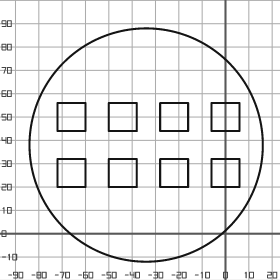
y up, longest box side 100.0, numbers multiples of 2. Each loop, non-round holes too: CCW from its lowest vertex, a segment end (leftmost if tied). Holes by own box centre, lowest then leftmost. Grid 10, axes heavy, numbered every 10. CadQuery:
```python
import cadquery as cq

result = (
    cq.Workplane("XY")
    .moveTo(-34.0, 38.0)
    .circle(50.0)
    .moveTo(-72.0, 20.0)
    .lineTo(-60.0, 20.0)
    .lineTo(-60.0, 32.0)
    .lineTo(-72.0, 32.0)
    .close()
    .moveTo(-50.0, 20.0)
    .lineTo(-38.0, 20.0)
    .lineTo(-38.0, 32.0)
    .lineTo(-50.0, 32.0)
    .close()
    .moveTo(-28.0, 20.0)
    .lineTo(-16.0, 20.0)
    .lineTo(-16.0, 32.0)
    .lineTo(-28.0, 32.0)
    .close()
    .moveTo(-6.0, 20.0)
    .lineTo(6.0, 20.0)
    .lineTo(6.0, 32.0)
    .lineTo(-6.0, 32.0)
    .close()
    .moveTo(-72.0, 44.0)
    .lineTo(-60.0, 44.0)
    .lineTo(-60.0, 56.0)
    .lineTo(-72.0, 56.0)
    .close()
    .moveTo(-50.0, 44.0)
    .lineTo(-38.0, 44.0)
    .lineTo(-38.0, 56.0)
    .lineTo(-50.0, 56.0)
    .close()
    .moveTo(-28.0, 44.0)
    .lineTo(-16.0, 44.0)
    .lineTo(-16.0, 56.0)
    .lineTo(-28.0, 56.0)
    .close()
    .moveTo(-6.0, 44.0)
    .lineTo(6.0, 44.0)
    .lineTo(6.0, 56.0)
    .lineTo(-6.0, 56.0)
    .close()
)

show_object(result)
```